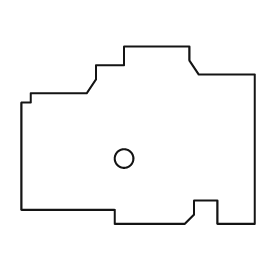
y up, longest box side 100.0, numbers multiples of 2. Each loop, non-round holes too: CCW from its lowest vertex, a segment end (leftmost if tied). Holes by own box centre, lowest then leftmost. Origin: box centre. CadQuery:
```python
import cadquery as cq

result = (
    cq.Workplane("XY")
    .moveTo(-10.0, -38.0)
    .lineTo(20.0, -38.0)
    .lineTo(24.0, -34.0)
    .lineTo(24.0, -28.0)
    .lineTo(34.0, -28.0)
    .lineTo(34.0, -38.0)
    .lineTo(50.0, -38.0)
    .lineTo(50.0, 26.0)
    .lineTo(26.0, 26.0)
    .lineTo(22.0, 32.0)
    .lineTo(22.0, 38.0)
    .lineTo(-6.0, 38.0)
    .lineTo(-6.0, 30.0)
    .lineTo(-18.0, 30.0)
    .lineTo(-18.0, 24.0)
    .lineTo(-22.0, 18.0)
    .lineTo(-46.0, 18.0)
    .lineTo(-46.0, 14.0)
    .lineTo(-50.0, 14.0)
    .lineTo(-50.0, -32.0)
    .lineTo(-10.0, -32.0)
    .close()
    .moveTo(-6.0, -10.0)
    .circle(4.0)
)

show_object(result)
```